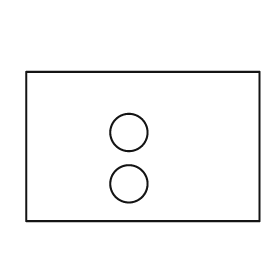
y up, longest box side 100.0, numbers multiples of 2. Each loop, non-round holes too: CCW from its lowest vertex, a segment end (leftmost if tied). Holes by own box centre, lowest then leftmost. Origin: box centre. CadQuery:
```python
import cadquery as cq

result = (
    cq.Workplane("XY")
    .moveTo(-50.0, -32.0)
    .lineTo(50.0, -32.0)
    .lineTo(50.0, 32.0)
    .lineTo(-50.0, 32.0)
    .close()
    .moveTo(-6.0, -16.0)
    .circle(8.0)
    .moveTo(-6.0, 6.0)
    .circle(8.0)
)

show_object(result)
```